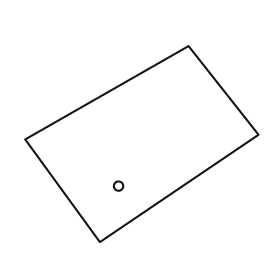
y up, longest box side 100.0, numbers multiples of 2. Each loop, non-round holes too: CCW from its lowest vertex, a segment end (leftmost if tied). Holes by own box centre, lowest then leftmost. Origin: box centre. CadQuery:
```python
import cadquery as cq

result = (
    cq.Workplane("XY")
    .moveTo(-18.0, -42.0)
    .lineTo(50.0, 4.0)
    .lineTo(20.0, 42.0)
    .lineTo(-50.0, 2.0)
    .close()
    .moveTo(-10.0, -18.0)
    .circle(2.0)
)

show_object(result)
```